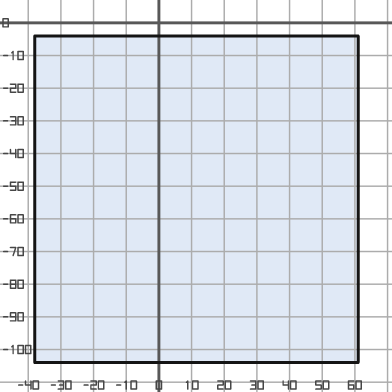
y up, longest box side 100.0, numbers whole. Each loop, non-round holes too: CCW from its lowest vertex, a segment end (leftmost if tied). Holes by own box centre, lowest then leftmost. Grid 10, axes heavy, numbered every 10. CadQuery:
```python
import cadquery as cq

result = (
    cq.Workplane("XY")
    .moveTo(-38.0, -104.0)
    .lineTo(61.0, -104.0)
    .lineTo(61.0, -4.0)
    .lineTo(-38.0, -4.0)
    .close()
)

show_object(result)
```